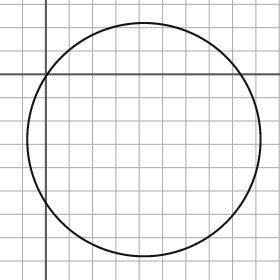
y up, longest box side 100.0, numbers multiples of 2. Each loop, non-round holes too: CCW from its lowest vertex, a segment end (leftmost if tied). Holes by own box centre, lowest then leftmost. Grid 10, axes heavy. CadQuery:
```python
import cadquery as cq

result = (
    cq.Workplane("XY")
    .moveTo(42.0, -28.0)
    .circle(50.0)
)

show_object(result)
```